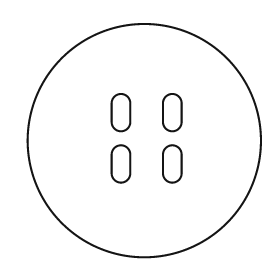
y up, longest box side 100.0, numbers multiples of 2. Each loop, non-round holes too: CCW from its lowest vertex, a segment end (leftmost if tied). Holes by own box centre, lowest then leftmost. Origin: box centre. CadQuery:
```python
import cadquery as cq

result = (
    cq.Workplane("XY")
    .moveTo(0.0, 0.0)
    .circle(50.0)
    .moveTo(-14.0, -14.0)
    .threePointArc((-10.0, -18.0), (-6.0, -14.0))
    .lineTo(-6.0, -6.0)
    .threePointArc((-10.0, -2.0), (-14.0, -6.0))
    .close()
    .moveTo(8.0, -14.0)
    .threePointArc((12.0, -18.0), (16.0, -14.0))
    .lineTo(16.0, -6.0)
    .threePointArc((12.0, -2.0), (8.0, -6.0))
    .close()
    .moveTo(-14.0, 8.0)
    .threePointArc((-10.0, 4.0), (-6.0, 8.0))
    .lineTo(-6.0, 16.0)
    .threePointArc((-10.0, 20.0), (-14.0, 16.0))
    .close()
    .moveTo(8.0, 8.0)
    .threePointArc((12.0, 4.0), (16.0, 8.0))
    .lineTo(16.0, 16.0)
    .threePointArc((12.0, 20.0), (8.0, 16.0))
    .close()
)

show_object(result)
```